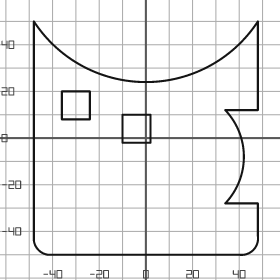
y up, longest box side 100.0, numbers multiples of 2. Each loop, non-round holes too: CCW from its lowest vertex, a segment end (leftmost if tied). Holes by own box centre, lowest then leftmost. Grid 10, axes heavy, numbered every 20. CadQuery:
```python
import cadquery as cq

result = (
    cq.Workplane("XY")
    .moveTo(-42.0, -50.0)
    .lineTo(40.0, -50.0)
    .threePointArc((46.0, -48.0), (48.0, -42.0))
    .lineTo(48.0, -28.0)
    .lineTo(34.0, -28.0)
    .threePointArc((42.0, -8.0), (34.0, 12.0))
    .lineTo(48.0, 12.0)
    .lineTo(48.0, 50.0)
    .threePointArc((0.0, 24.0), (-48.0, 50.0))
    .lineTo(-48.0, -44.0)
    .threePointArc((-46.0, -48.0), (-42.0, -50.0))
    .close()
    .moveTo(-10.0, -2.0)
    .lineTo(2.0, -2.0)
    .lineTo(2.0, 10.0)
    .lineTo(-10.0, 10.0)
    .close()
    .moveTo(-36.0, 8.0)
    .lineTo(-24.0, 8.0)
    .lineTo(-24.0, 20.0)
    .lineTo(-36.0, 20.0)
    .close()
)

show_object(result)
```